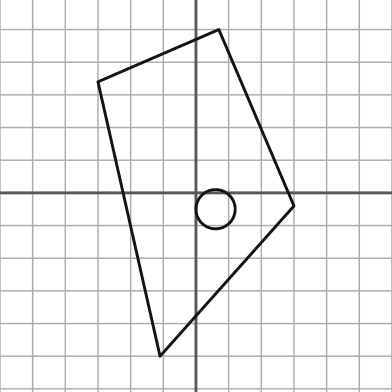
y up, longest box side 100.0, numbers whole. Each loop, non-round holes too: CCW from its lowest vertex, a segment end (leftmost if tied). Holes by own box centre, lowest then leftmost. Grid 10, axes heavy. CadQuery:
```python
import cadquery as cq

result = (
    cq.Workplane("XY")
    .moveTo(-11.0, -50.0)
    .lineTo(30.0, -4.0)
    .lineTo(7.0, 50.0)
    .lineTo(-30.0, 34.0)
    .close()
    .moveTo(6.0, -5.0)
    .circle(6.0)
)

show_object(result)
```